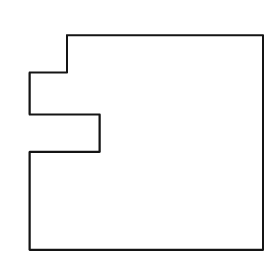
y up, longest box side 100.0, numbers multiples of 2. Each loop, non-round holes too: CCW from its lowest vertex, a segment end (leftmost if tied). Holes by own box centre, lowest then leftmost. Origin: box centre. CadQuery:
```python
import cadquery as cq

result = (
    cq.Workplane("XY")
    .moveTo(-50.0, -46.0)
    .lineTo(50.0, -46.0)
    .lineTo(50.0, 46.0)
    .lineTo(-34.0, 46.0)
    .lineTo(-34.0, 30.0)
    .lineTo(-50.0, 30.0)
    .lineTo(-50.0, 12.0)
    .lineTo(-20.0, 12.0)
    .lineTo(-20.0, -4.0)
    .lineTo(-50.0, -4.0)
    .close()
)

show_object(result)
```